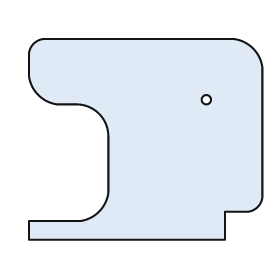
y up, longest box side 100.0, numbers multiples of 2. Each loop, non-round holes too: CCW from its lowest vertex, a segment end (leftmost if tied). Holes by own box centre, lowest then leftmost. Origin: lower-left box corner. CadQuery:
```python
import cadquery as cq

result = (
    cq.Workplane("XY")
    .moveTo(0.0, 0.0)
    .lineTo(84.0, 0.0)
    .lineTo(84.0, 12.0)
    .lineTo(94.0, 12.0)
    .threePointArc((98.0, 14.0), (100.0, 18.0))
    .lineTo(100.0, 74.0)
    .threePointArc((96.0, 82.0), (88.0, 86.0))
    .lineTo(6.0, 86.0)
    .threePointArc((2.0, 84.0), (0.0, 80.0))
    .lineTo(0.0, 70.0)
    .threePointArc((4.0, 62.0), (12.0, 58.0))
    .lineTo(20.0, 58.0)
    .threePointArc((30.0, 54.0), (34.0, 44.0))
    .lineTo(34.0, 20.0)
    .threePointArc((30.0, 12.0), (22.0, 8.0))
    .lineTo(0.0, 8.0)
    .close()
    .moveTo(76.0, 60.0)
    .circle(2.0)
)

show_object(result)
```